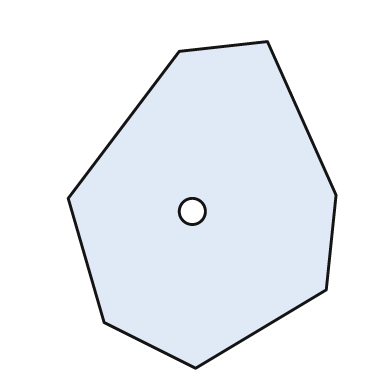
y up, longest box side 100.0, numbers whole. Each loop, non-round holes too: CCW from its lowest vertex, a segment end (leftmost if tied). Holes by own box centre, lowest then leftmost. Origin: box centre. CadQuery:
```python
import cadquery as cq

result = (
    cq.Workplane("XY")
    .moveTo(-2.0, -50.0)
    .lineTo(38.0, -26.0)
    .lineTo(41.0, 3.0)
    .lineTo(20.0, 50.0)
    .lineTo(-7.0, 47.0)
    .lineTo(-41.0, 2.0)
    .lineTo(-30.0, -36.0)
    .close()
    .moveTo(-3.0, -2.0)
    .circle(4.0)
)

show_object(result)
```